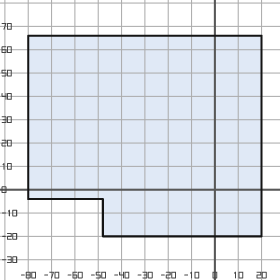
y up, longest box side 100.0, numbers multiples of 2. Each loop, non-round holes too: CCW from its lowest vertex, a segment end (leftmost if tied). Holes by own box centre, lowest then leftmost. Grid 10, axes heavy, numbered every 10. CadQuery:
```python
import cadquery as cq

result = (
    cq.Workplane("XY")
    .moveTo(-48.0, -20.0)
    .lineTo(20.0, -20.0)
    .lineTo(20.0, 66.0)
    .lineTo(-80.0, 66.0)
    .lineTo(-80.0, -4.0)
    .lineTo(-48.0, -4.0)
    .close()
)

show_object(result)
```